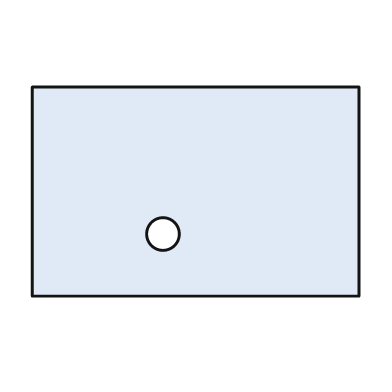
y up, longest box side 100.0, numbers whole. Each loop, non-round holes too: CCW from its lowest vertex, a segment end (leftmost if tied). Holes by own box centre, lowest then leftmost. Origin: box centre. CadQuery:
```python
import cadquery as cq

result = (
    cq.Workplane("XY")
    .moveTo(-50.0, -32.0)
    .lineTo(50.0, -32.0)
    .lineTo(50.0, 32.0)
    .lineTo(-50.0, 32.0)
    .close()
    .moveTo(-10.0, -13.0)
    .circle(5.0)
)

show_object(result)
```